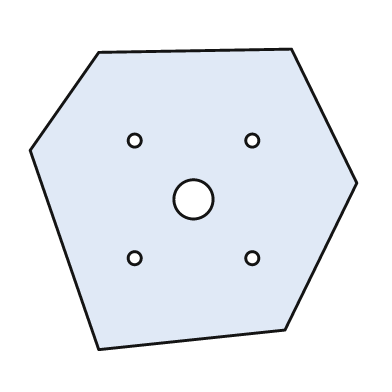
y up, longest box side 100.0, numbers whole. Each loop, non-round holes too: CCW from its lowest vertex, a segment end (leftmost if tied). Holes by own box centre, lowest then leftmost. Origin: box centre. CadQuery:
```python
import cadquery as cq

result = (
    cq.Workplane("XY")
    .moveTo(-29.0, -46.0)
    .lineTo(28.0, -40.0)
    .lineTo(50.0, 5.0)
    .lineTo(30.0, 46.0)
    .lineTo(-29.0, 45.0)
    .lineTo(-50.0, 15.0)
    .close()
    .moveTo(-18.0, -18.0)
    .circle(2.0)
    .moveTo(18.0, -18.0)
    .circle(2.0)
    .moveTo(0.0, 0.0)
    .circle(6.0)
    .moveTo(-18.0, 18.0)
    .circle(2.0)
    .moveTo(18.0, 18.0)
    .circle(2.0)
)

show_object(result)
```